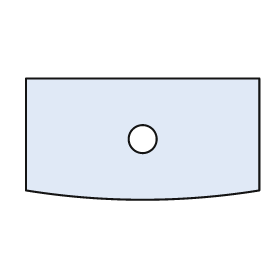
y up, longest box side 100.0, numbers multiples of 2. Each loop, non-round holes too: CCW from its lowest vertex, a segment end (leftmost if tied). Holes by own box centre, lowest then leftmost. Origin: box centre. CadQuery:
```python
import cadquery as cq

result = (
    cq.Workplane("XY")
    .moveTo(-50.0, -22.0)
    .threePointArc((0.0, -26.0), (50.0, -22.0))
    .lineTo(50.0, 26.0)
    .lineTo(-50.0, 26.0)
    .close()
    .moveTo(0.0, 0.0)
    .circle(6.0)
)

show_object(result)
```